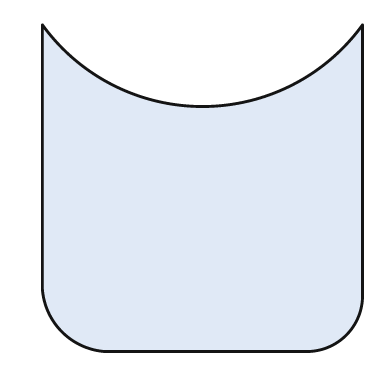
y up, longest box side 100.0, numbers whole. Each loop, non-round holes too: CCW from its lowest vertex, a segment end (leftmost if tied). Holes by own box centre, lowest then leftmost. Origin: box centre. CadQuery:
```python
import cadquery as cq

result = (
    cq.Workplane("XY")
    .moveTo(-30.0, -50.0)
    .lineTo(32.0, -50.0)
    .threePointArc((44.0, -45.0), (49.0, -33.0))
    .lineTo(49.0, 50.0)
    .threePointArc((0.0, 25.0), (-49.0, 50.0))
    .lineTo(-49.0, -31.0)
    .threePointArc((-43.0, -44.0), (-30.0, -50.0))
    .close()
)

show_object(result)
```